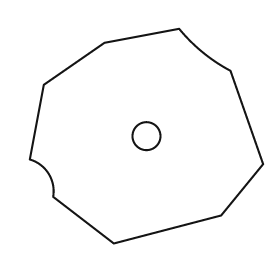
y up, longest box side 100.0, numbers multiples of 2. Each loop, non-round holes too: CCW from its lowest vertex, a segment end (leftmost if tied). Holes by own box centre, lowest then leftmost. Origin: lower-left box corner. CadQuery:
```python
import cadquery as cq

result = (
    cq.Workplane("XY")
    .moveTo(36.0, 0.0)
    .lineTo(82.0, 12.0)
    .lineTo(100.0, 34.0)
    .lineTo(86.0, 74.0)
    .threePointArc((74.0, 82.0), (64.0, 92.0))
    .lineTo(32.0, 86.0)
    .lineTo(6.0, 68.0)
    .lineTo(0.0, 36.0)
    .threePointArc((8.0, 30.0), (10.0, 20.0))
    .close()
    .moveTo(50.0, 46.0)
    .circle(6.0)
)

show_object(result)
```